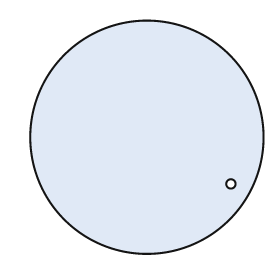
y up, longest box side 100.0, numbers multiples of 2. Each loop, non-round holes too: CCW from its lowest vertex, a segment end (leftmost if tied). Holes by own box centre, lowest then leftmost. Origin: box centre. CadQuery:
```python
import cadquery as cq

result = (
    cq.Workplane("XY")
    .moveTo(0.0, 0.0)
    .circle(50.0)
    .moveTo(36.0, -20.0)
    .circle(2.0)
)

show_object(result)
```